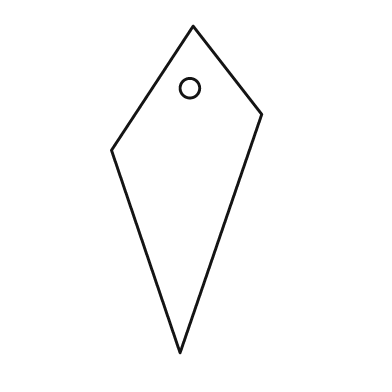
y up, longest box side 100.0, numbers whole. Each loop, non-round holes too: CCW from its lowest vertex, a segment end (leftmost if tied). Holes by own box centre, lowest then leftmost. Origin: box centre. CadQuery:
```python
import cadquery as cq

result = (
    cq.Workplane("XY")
    .moveTo(-2.0, -50.0)
    .lineTo(23.0, 23.0)
    .lineTo(2.0, 50.0)
    .lineTo(-23.0, 12.0)
    .close()
    .moveTo(1.0, 31.0)
    .circle(3.0)
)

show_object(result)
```